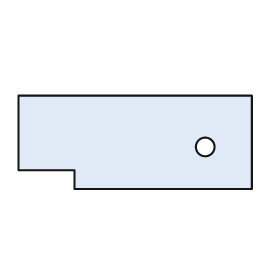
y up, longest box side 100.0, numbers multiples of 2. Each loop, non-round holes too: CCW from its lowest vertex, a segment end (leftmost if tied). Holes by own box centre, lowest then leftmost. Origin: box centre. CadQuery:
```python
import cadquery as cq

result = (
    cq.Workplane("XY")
    .moveTo(-26.0, -20.0)
    .lineTo(50.0, -20.0)
    .lineTo(50.0, 20.0)
    .lineTo(-50.0, 20.0)
    .lineTo(-50.0, -12.0)
    .lineTo(-26.0, -12.0)
    .close()
    .moveTo(30.0, -2.0)
    .circle(4.0)
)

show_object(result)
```